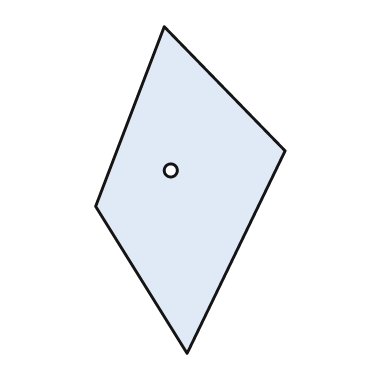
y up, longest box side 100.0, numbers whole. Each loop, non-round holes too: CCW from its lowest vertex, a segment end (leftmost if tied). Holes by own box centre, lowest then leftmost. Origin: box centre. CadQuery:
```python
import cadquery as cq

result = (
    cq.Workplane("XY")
    .moveTo(-1.0, -50.0)
    .lineTo(29.0, 12.0)
    .lineTo(-8.0, 50.0)
    .lineTo(-29.0, -5.0)
    .close()
    .moveTo(-6.0, 6.0)
    .circle(2.0)
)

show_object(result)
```